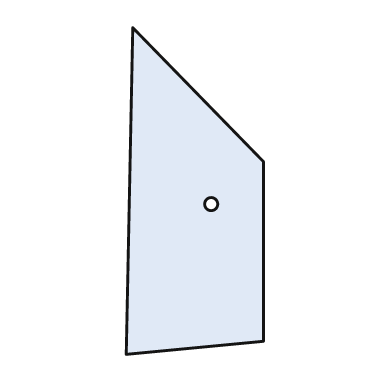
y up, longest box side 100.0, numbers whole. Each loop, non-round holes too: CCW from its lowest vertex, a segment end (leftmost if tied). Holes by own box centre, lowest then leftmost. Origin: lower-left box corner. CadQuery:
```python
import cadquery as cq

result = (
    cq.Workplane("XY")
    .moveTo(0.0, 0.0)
    .lineTo(42.0, 4.0)
    .lineTo(42.0, 59.0)
    .lineTo(2.0, 100.0)
    .close()
    .moveTo(26.0, 46.0)
    .circle(2.0)
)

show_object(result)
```